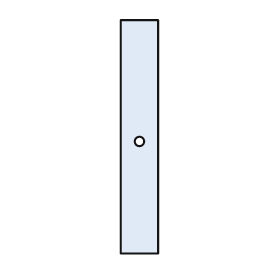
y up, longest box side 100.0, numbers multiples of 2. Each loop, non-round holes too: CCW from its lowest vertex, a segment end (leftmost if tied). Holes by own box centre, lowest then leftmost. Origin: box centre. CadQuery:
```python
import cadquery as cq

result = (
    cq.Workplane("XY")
    .moveTo(-8.0, -50.0)
    .lineTo(8.0, -50.0)
    .lineTo(8.0, 50.0)
    .lineTo(-8.0, 50.0)
    .close()
    .moveTo(0.0, -2.0)
    .circle(2.0)
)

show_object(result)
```